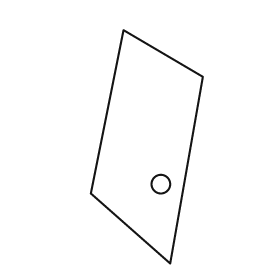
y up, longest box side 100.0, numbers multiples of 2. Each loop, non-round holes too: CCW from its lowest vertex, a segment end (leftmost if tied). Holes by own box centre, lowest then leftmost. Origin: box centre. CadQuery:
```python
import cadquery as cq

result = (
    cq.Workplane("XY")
    .moveTo(10.0, -50.0)
    .lineTo(24.0, 30.0)
    .lineTo(-10.0, 50.0)
    .lineTo(-24.0, -20.0)
    .close()
    .moveTo(6.0, -16.0)
    .circle(4.0)
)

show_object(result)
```